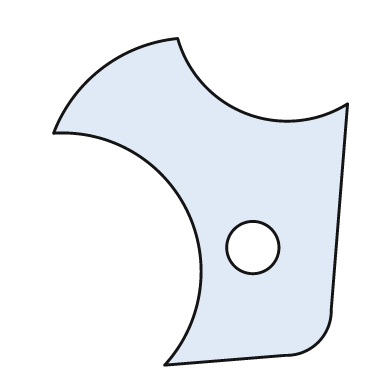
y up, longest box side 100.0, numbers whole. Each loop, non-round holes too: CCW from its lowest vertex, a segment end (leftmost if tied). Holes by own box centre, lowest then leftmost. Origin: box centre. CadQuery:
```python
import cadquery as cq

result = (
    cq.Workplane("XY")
    .moveTo(-11.0, -50.0)
    .lineTo(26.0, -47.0)
    .threePointArc((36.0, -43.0), (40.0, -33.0))
    .lineTo(45.0, 30.0)
    .threePointArc((14.0, 27.0), (-7.0, 50.0))
    .threePointArc((-30.0, 41.0), (-45.0, 21.0))
    .threePointArc((-4.0, -3.0), (-11.0, -50.0))
    .close()
    .moveTo(16.0, -14.0)
    .circle(8.0)
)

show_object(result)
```